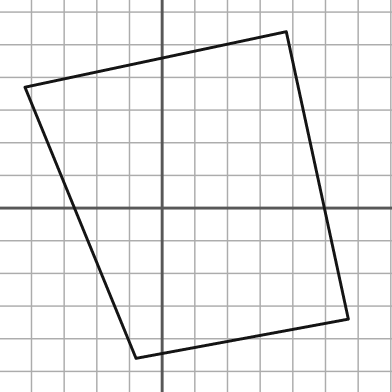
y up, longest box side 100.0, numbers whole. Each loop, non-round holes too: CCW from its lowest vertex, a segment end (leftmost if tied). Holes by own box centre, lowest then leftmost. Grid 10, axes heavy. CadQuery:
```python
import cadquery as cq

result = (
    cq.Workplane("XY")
    .moveTo(-8.0, -46.0)
    .lineTo(57.0, -34.0)
    .lineTo(38.0, 54.0)
    .lineTo(-42.0, 37.0)
    .close()
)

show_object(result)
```